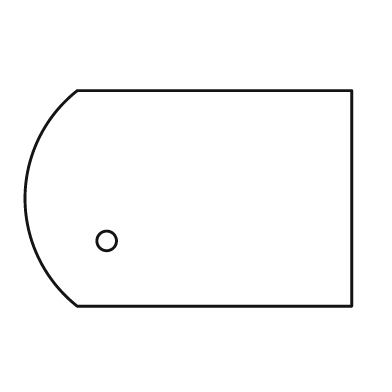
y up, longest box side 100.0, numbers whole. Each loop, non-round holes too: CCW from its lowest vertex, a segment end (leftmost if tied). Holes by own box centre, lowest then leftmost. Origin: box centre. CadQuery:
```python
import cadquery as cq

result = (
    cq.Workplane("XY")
    .moveTo(-34.0, -33.0)
    .lineTo(50.0, -33.0)
    .lineTo(50.0, 33.0)
    .lineTo(-34.0, 33.0)
    .threePointArc((-50.0, 0.0), (-34.0, -33.0))
    .close()
    .moveTo(-25.0, -13.0)
    .circle(3.0)
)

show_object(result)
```